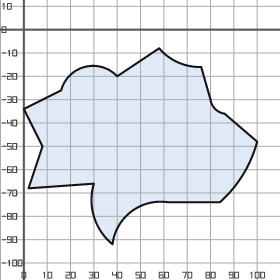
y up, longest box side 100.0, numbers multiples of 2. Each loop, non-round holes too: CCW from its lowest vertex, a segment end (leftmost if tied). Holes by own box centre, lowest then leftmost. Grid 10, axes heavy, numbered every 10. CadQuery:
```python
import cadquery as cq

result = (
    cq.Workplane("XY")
    .moveTo(38.0, -92.0)
    .threePointArc((46.0, -78.0), (62.0, -74.0))
    .lineTo(84.0, -74.0)
    .threePointArc((94.0, -62.0), (100.0, -48.0))
    .lineTo(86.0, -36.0)
    .threePointArc((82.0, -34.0), (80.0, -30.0))
    .lineTo(76.0, -16.0)
    .threePointArc((66.0, -14.0), (58.0, -8.0))
    .lineTo(40.0, -20.0)
    .threePointArc((26.0, -16.0), (16.0, -26.0))
    .lineTo(0.0, -34.0)
    .lineTo(8.0, -50.0)
    .lineTo(2.0, -68.0)
    .lineTo(30.0, -66.0)
    .threePointArc((30.0, -80.0), (38.0, -92.0))
    .close()
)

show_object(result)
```